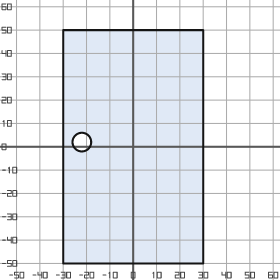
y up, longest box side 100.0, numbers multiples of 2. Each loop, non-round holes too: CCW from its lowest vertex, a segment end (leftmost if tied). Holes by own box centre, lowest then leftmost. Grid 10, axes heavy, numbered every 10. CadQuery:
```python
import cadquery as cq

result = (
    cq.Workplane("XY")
    .moveTo(-30.0, -50.0)
    .lineTo(30.0, -50.0)
    .lineTo(30.0, 50.0)
    .lineTo(-30.0, 50.0)
    .close()
    .moveTo(-22.0, 2.0)
    .circle(4.0)
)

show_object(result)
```